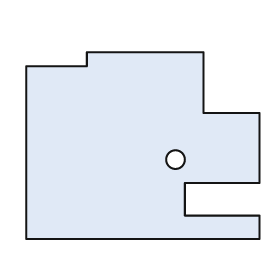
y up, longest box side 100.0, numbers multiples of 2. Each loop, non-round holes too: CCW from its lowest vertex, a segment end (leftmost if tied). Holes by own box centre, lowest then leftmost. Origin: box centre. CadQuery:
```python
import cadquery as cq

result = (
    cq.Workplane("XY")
    .moveTo(-50.0, -40.0)
    .lineTo(50.0, -40.0)
    .lineTo(50.0, -30.0)
    .lineTo(18.0, -30.0)
    .lineTo(18.0, -16.0)
    .lineTo(50.0, -16.0)
    .lineTo(50.0, 14.0)
    .lineTo(26.0, 14.0)
    .lineTo(26.0, 40.0)
    .lineTo(-24.0, 40.0)
    .lineTo(-24.0, 34.0)
    .lineTo(-50.0, 34.0)
    .close()
    .moveTo(14.0, -6.0)
    .circle(4.0)
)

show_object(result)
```